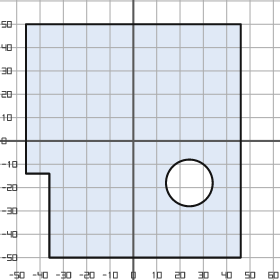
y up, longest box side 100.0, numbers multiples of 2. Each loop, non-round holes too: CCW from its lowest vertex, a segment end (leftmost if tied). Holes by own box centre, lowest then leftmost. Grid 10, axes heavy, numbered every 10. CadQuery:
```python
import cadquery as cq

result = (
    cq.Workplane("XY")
    .moveTo(-36.0, -50.0)
    .lineTo(46.0, -50.0)
    .lineTo(46.0, 50.0)
    .lineTo(-46.0, 50.0)
    .lineTo(-46.0, -14.0)
    .lineTo(-36.0, -14.0)
    .close()
    .moveTo(24.0, -18.0)
    .circle(10.0)
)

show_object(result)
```